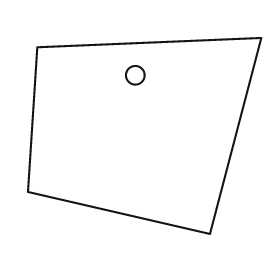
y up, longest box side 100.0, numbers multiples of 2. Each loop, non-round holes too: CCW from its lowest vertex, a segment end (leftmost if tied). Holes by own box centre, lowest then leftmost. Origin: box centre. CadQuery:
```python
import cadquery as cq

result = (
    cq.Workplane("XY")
    .moveTo(28.0, -42.0)
    .lineTo(50.0, 42.0)
    .lineTo(-46.0, 38.0)
    .lineTo(-50.0, -24.0)
    .close()
    .moveTo(-4.0, 26.0)
    .circle(4.0)
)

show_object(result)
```